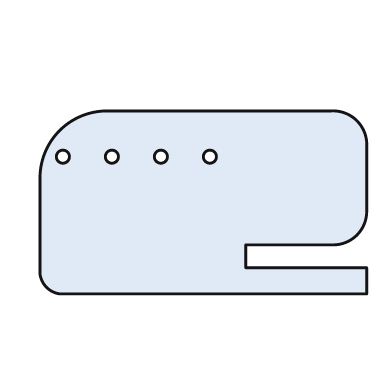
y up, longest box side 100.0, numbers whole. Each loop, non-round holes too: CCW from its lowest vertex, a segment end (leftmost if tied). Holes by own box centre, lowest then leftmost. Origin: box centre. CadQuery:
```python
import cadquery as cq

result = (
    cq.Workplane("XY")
    .moveTo(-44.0, -28.0)
    .lineTo(50.0, -28.0)
    .lineTo(50.0, -20.0)
    .lineTo(13.0, -20.0)
    .lineTo(13.0, -13.0)
    .lineTo(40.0, -13.0)
    .threePointArc((47.0, -10.0), (50.0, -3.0))
    .lineTo(50.0, 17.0)
    .threePointArc((47.0, 25.0), (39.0, 28.0))
    .lineTo(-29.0, 28.0)
    .threePointArc((-44.0, 22.0), (-50.0, 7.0))
    .lineTo(-50.0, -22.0)
    .threePointArc((-48.0, -26.0), (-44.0, -28.0))
    .close()
    .moveTo(-43.0, 14.0)
    .circle(2.0)
    .moveTo(-28.0, 14.0)
    .circle(2.0)
    .moveTo(-13.0, 14.0)
    .circle(2.0)
    .moveTo(2.0, 14.0)
    .circle(2.0)
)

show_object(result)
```